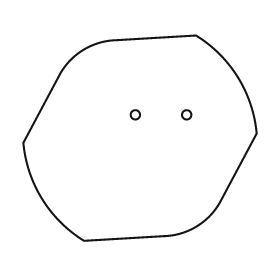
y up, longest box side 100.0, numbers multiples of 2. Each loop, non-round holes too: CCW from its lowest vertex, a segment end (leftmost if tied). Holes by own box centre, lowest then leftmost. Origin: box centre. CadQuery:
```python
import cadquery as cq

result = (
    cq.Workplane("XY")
    .moveTo(-24.0, -44.0)
    .lineTo(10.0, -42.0)
    .threePointArc((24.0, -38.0), (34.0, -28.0))
    .lineTo(50.0, 2.0)
    .threePointArc((42.0, 26.0), (24.0, 44.0))
    .lineTo(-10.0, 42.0)
    .threePointArc((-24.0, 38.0), (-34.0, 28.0))
    .lineTo(-50.0, -2.0)
    .threePointArc((-42.0, -26.0), (-24.0, -44.0))
    .close()
    .moveTo(-2.0, 10.0)
    .circle(2.0)
    .moveTo(20.0, 10.0)
    .circle(2.0)
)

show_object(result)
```